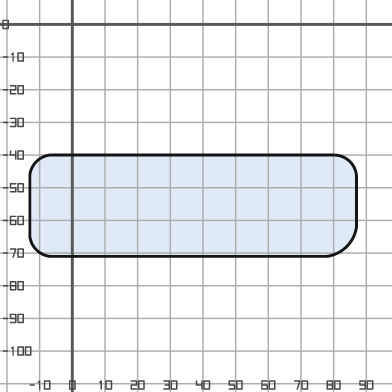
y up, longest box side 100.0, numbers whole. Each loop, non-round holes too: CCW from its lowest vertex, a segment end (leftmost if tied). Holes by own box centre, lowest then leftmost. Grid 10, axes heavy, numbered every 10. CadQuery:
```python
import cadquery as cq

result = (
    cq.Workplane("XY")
    .moveTo(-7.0, -71.0)
    .lineTo(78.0, -71.0)
    .threePointArc((84.0, -68.0), (87.0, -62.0))
    .lineTo(87.0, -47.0)
    .threePointArc((85.0, -42.0), (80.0, -40.0))
    .lineTo(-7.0, -40.0)
    .threePointArc((-11.0, -42.0), (-13.0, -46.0))
    .lineTo(-13.0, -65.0)
    .threePointArc((-11.0, -69.0), (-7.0, -71.0))
    .close()
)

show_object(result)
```